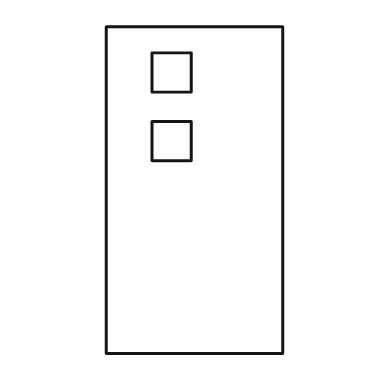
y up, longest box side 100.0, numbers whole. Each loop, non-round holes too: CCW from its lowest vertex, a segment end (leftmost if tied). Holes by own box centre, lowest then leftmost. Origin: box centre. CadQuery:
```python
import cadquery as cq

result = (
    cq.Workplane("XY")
    .moveTo(-27.0, -50.0)
    .lineTo(27.0, -50.0)
    .lineTo(27.0, 50.0)
    .lineTo(-27.0, 50.0)
    .close()
    .moveTo(-13.0, 9.0)
    .lineTo(-1.0, 9.0)
    .lineTo(-1.0, 21.0)
    .lineTo(-13.0, 21.0)
    .close()
    .moveTo(-13.0, 30.0)
    .lineTo(-1.0, 30.0)
    .lineTo(-1.0, 42.0)
    .lineTo(-13.0, 42.0)
    .close()
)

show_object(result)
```